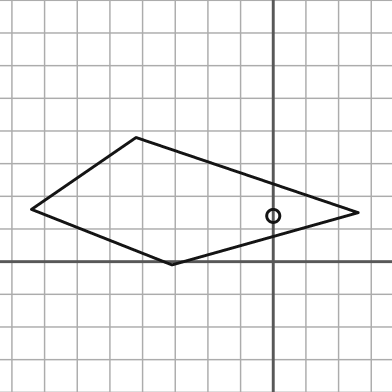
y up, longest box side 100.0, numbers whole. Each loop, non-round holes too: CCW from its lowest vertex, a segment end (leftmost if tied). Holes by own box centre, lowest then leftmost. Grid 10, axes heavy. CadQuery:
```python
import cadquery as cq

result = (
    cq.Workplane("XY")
    .moveTo(-31.0, -1.0)
    .lineTo(26.0, 15.0)
    .lineTo(-42.0, 38.0)
    .lineTo(-74.0, 16.0)
    .close()
    .moveTo(0.0, 14.0)
    .circle(2.0)
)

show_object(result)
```